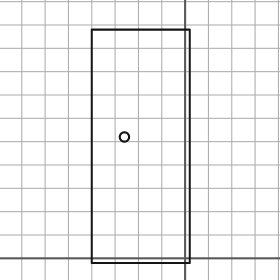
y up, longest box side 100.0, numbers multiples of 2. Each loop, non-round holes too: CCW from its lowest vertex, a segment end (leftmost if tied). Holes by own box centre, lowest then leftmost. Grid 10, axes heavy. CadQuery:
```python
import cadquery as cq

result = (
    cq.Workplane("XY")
    .moveTo(-40.0, -2.0)
    .lineTo(2.0, -2.0)
    .lineTo(2.0, 98.0)
    .lineTo(-40.0, 98.0)
    .close()
    .moveTo(-26.0, 52.0)
    .circle(2.0)
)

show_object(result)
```